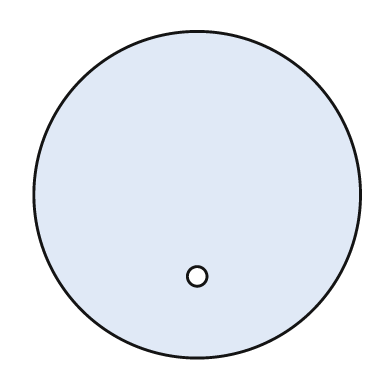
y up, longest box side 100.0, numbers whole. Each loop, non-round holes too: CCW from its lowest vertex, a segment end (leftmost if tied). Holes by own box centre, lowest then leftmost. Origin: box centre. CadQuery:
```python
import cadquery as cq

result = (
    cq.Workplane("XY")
    .moveTo(0.0, 0.0)
    .circle(50.0)
    .moveTo(0.0, -25.0)
    .circle(3.0)
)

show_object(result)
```